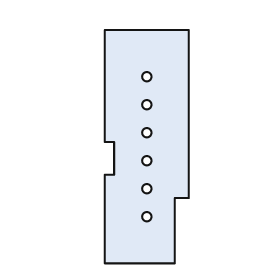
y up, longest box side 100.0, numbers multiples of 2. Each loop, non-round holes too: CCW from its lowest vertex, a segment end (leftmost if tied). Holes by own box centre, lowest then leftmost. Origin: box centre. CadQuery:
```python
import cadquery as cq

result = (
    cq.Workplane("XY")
    .moveTo(-18.0, -50.0)
    .lineTo(12.0, -50.0)
    .lineTo(12.0, -22.0)
    .lineTo(18.0, -22.0)
    .lineTo(18.0, 50.0)
    .lineTo(-18.0, 50.0)
    .lineTo(-18.0, 2.0)
    .lineTo(-14.0, 2.0)
    .lineTo(-14.0, -12.0)
    .lineTo(-18.0, -12.0)
    .close()
    .moveTo(0.0, -30.0)
    .circle(2.0)
    .moveTo(0.0, -18.0)
    .circle(2.0)
    .moveTo(0.0, -6.0)
    .circle(2.0)
    .moveTo(0.0, 6.0)
    .circle(2.0)
    .moveTo(0.0, 18.0)
    .circle(2.0)
    .moveTo(0.0, 30.0)
    .circle(2.0)
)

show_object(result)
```